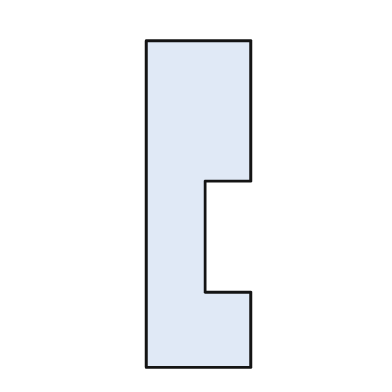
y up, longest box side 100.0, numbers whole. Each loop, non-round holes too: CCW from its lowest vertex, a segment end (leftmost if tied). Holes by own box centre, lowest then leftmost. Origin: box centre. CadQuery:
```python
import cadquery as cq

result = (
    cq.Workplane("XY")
    .moveTo(-16.0, -50.0)
    .lineTo(16.0, -50.0)
    .lineTo(16.0, -27.0)
    .lineTo(2.0, -27.0)
    .lineTo(2.0, 7.0)
    .lineTo(16.0, 7.0)
    .lineTo(16.0, 50.0)
    .lineTo(-16.0, 50.0)
    .close()
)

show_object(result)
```